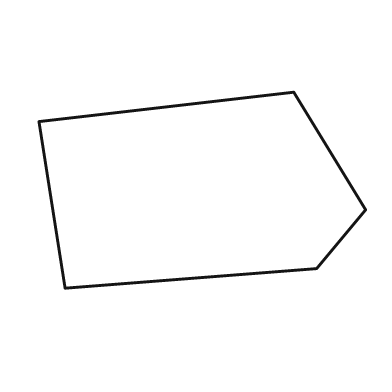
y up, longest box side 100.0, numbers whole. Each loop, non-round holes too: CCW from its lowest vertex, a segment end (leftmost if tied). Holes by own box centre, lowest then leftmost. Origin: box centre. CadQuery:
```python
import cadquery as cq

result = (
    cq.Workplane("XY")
    .moveTo(-42.0, -30.0)
    .lineTo(35.0, -24.0)
    .lineTo(50.0, -6.0)
    .lineTo(28.0, 30.0)
    .lineTo(-50.0, 21.0)
    .close()
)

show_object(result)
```